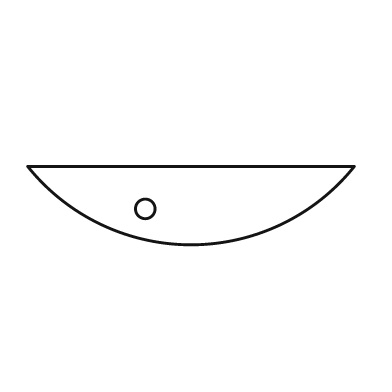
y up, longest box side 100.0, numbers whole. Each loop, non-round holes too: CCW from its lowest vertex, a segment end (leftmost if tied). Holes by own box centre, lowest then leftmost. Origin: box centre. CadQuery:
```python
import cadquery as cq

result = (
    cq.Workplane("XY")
    .moveTo(-50.0, 12.0)
    .threePointArc((0.0, -12.0), (50.0, 12.0))
    .close()
    .moveTo(-14.0, -1.0)
    .circle(3.0)
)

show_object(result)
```